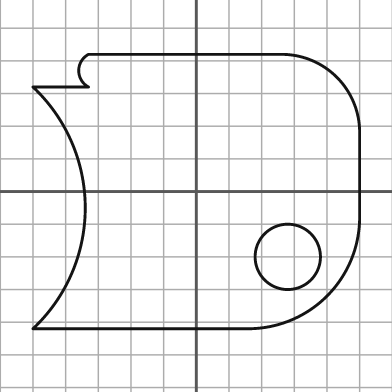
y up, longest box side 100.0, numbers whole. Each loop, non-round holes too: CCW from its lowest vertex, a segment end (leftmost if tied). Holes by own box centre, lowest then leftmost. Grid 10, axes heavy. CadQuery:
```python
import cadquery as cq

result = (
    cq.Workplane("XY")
    .moveTo(-50.0, -42.0)
    .lineTo(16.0, -42.0)
    .threePointArc((40.0, -32.0), (50.0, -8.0))
    .lineTo(50.0, 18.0)
    .threePointArc((43.0, 35.0), (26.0, 42.0))
    .lineTo(-33.0, 42.0)
    .threePointArc((-36.0, 37.0), (-33.0, 32.0))
    .lineTo(-50.0, 32.0)
    .threePointArc((-34.0, -5.0), (-50.0, -42.0))
    .close()
    .moveTo(28.0, -20.0)
    .circle(10.0)
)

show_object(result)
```